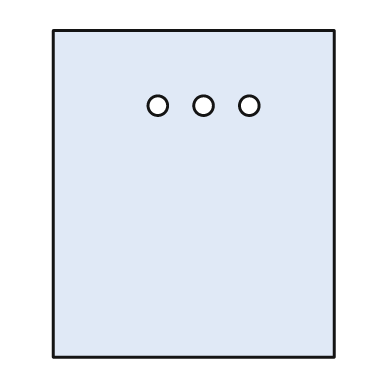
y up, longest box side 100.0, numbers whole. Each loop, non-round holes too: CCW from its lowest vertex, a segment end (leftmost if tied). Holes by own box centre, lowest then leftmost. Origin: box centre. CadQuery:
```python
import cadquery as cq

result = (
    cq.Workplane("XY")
    .moveTo(-43.0, -50.0)
    .lineTo(43.0, -50.0)
    .lineTo(43.0, 50.0)
    .lineTo(-43.0, 50.0)
    .close()
    .moveTo(-11.0, 27.0)
    .circle(3.0)
    .moveTo(3.0, 27.0)
    .circle(3.0)
    .moveTo(17.0, 27.0)
    .circle(3.0)
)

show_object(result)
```